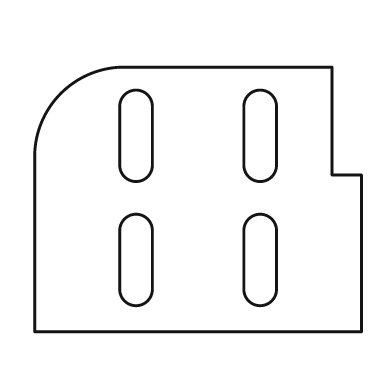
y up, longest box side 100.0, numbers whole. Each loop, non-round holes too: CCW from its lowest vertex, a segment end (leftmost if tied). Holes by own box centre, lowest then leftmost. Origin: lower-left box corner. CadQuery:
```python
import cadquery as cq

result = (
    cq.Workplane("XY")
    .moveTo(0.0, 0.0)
    .lineTo(100.0, 0.0)
    .lineTo(100.0, 48.0)
    .lineTo(91.0, 48.0)
    .lineTo(91.0, 81.0)
    .lineTo(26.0, 81.0)
    .threePointArc((8.0, 73.0), (0.0, 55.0))
    .close()
    .moveTo(26.0, 13.0)
    .threePointArc((31.0, 8.0), (36.0, 13.0))
    .lineTo(36.0, 31.0)
    .threePointArc((31.0, 36.0), (26.0, 31.0))
    .close()
    .moveTo(64.0, 13.0)
    .threePointArc((69.0, 8.0), (74.0, 13.0))
    .lineTo(74.0, 31.0)
    .threePointArc((69.0, 36.0), (64.0, 31.0))
    .close()
    .moveTo(26.0, 51.0)
    .threePointArc((31.0, 46.0), (36.0, 51.0))
    .lineTo(36.0, 69.0)
    .threePointArc((31.0, 74.0), (26.0, 69.0))
    .close()
    .moveTo(64.0, 51.0)
    .threePointArc((69.0, 46.0), (74.0, 51.0))
    .lineTo(74.0, 69.0)
    .threePointArc((69.0, 74.0), (64.0, 69.0))
    .close()
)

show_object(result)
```